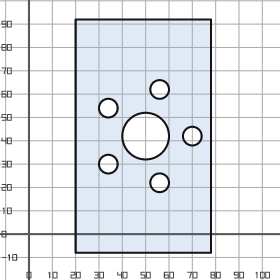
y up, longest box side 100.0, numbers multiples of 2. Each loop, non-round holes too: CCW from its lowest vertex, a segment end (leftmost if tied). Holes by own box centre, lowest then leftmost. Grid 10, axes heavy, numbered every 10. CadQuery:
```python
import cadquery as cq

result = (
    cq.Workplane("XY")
    .moveTo(20.0, -8.0)
    .lineTo(78.0, -8.0)
    .lineTo(78.0, 92.0)
    .lineTo(20.0, 92.0)
    .close()
    .moveTo(56.0, 22.0)
    .circle(4.0)
    .moveTo(34.0, 30.0)
    .circle(4.0)
    .moveTo(50.0, 42.0)
    .circle(10.0)
    .moveTo(70.0, 42.0)
    .circle(4.0)
    .moveTo(34.0, 54.0)
    .circle(4.0)
    .moveTo(56.0, 62.0)
    .circle(4.0)
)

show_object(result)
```